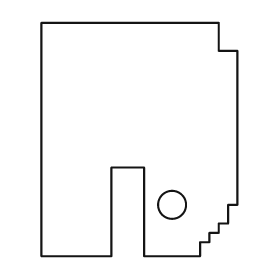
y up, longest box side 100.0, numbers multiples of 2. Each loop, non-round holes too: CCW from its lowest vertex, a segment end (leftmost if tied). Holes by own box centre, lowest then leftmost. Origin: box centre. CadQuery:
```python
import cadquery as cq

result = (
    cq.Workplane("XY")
    .moveTo(-42.0, -50.0)
    .lineTo(-12.0, -50.0)
    .lineTo(-12.0, -12.0)
    .lineTo(2.0, -12.0)
    .lineTo(2.0, -50.0)
    .lineTo(26.0, -50.0)
    .lineTo(26.0, -44.0)
    .lineTo(30.0, -44.0)
    .lineTo(30.0, -40.0)
    .lineTo(34.0, -40.0)
    .lineTo(34.0, -36.0)
    .lineTo(38.0, -36.0)
    .lineTo(38.0, -28.0)
    .lineTo(42.0, -28.0)
    .lineTo(42.0, 38.0)
    .lineTo(34.0, 38.0)
    .lineTo(34.0, 50.0)
    .lineTo(-42.0, 50.0)
    .close()
    .moveTo(14.0, -28.0)
    .circle(6.0)
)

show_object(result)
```